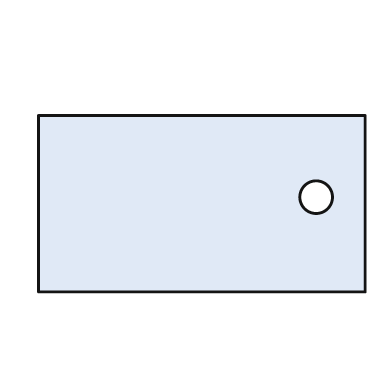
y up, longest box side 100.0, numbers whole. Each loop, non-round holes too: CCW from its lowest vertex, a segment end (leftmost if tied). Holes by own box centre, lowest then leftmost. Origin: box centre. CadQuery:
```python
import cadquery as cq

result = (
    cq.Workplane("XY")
    .moveTo(-50.0, -27.0)
    .lineTo(50.0, -27.0)
    .lineTo(50.0, 27.0)
    .lineTo(-50.0, 27.0)
    .close()
    .moveTo(35.0, 2.0)
    .circle(5.0)
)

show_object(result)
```